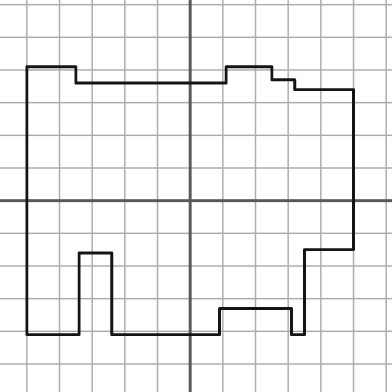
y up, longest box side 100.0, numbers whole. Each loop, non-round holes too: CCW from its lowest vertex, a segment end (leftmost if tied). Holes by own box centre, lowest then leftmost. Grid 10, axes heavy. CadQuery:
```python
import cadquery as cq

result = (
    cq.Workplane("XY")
    .moveTo(-50.0, -41.0)
    .lineTo(-34.0, -41.0)
    .lineTo(-34.0, -16.0)
    .lineTo(-24.0, -16.0)
    .lineTo(-24.0, -41.0)
    .lineTo(9.0, -41.0)
    .lineTo(9.0, -33.0)
    .lineTo(31.0, -33.0)
    .lineTo(31.0, -41.0)
    .lineTo(35.0, -41.0)
    .lineTo(35.0, -15.0)
    .lineTo(50.0, -15.0)
    .lineTo(50.0, 34.0)
    .lineTo(32.0, 34.0)
    .lineTo(32.0, 37.0)
    .lineTo(25.0, 37.0)
    .lineTo(25.0, 41.0)
    .lineTo(11.0, 41.0)
    .lineTo(11.0, 36.0)
    .lineTo(-35.0, 36.0)
    .lineTo(-35.0, 41.0)
    .lineTo(-50.0, 41.0)
    .close()
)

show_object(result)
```